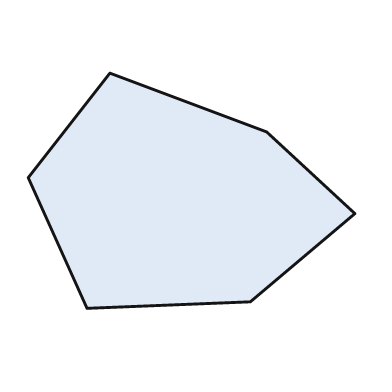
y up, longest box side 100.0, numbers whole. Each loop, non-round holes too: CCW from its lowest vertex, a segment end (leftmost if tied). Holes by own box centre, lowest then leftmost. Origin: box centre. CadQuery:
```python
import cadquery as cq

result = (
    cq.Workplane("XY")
    .moveTo(-32.0, -36.0)
    .lineTo(18.0, -34.0)
    .lineTo(50.0, -7.0)
    .lineTo(23.0, 18.0)
    .lineTo(-25.0, 36.0)
    .lineTo(-50.0, 4.0)
    .close()
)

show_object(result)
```